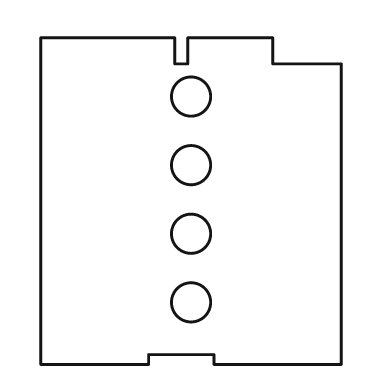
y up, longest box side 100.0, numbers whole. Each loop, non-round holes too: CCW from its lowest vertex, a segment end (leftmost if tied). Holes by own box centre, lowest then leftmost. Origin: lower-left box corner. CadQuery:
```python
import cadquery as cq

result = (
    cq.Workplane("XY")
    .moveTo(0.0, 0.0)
    .lineTo(33.0, 0.0)
    .lineTo(33.0, 3.0)
    .lineTo(53.0, 3.0)
    .lineTo(53.0, 0.0)
    .lineTo(92.0, 0.0)
    .lineTo(92.0, 92.0)
    .lineTo(71.0, 92.0)
    .lineTo(71.0, 100.0)
    .lineTo(45.0, 100.0)
    .lineTo(45.0, 92.0)
    .lineTo(41.0, 92.0)
    .lineTo(41.0, 100.0)
    .lineTo(0.0, 100.0)
    .close()
    .moveTo(46.0, 19.0)
    .circle(6.0)
    .moveTo(46.0, 40.0)
    .circle(6.0)
    .moveTo(46.0, 61.0)
    .circle(6.0)
    .moveTo(46.0, 82.0)
    .circle(6.0)
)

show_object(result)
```